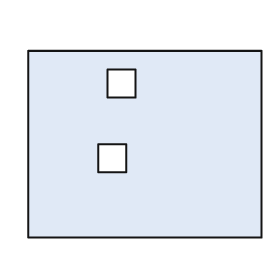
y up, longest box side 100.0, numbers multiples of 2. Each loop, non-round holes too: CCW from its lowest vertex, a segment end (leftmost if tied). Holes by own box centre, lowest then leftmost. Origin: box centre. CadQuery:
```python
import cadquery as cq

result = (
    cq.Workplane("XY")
    .moveTo(-50.0, -40.0)
    .lineTo(50.0, -40.0)
    .lineTo(50.0, 40.0)
    .lineTo(-50.0, 40.0)
    .close()
    .moveTo(-20.0, -12.0)
    .lineTo(-8.0, -12.0)
    .lineTo(-8.0, 0.0)
    .lineTo(-20.0, 0.0)
    .close()
    .moveTo(-16.0, 20.0)
    .lineTo(-4.0, 20.0)
    .lineTo(-4.0, 32.0)
    .lineTo(-16.0, 32.0)
    .close()
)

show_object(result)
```